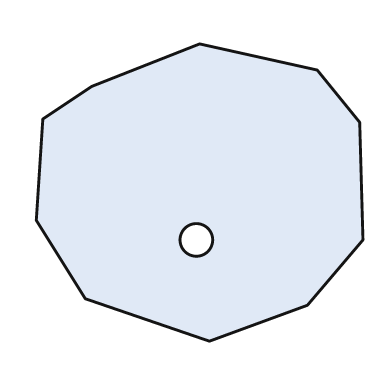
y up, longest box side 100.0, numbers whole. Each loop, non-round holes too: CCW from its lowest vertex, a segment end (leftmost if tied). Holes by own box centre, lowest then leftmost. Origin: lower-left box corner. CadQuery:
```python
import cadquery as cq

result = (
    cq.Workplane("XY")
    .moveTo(53.0, 0.0)
    .lineTo(83.0, 11.0)
    .lineTo(100.0, 31.0)
    .lineTo(99.0, 67.0)
    .lineTo(86.0, 83.0)
    .lineTo(50.0, 91.0)
    .lineTo(17.0, 78.0)
    .lineTo(2.0, 68.0)
    .lineTo(0.0, 37.0)
    .lineTo(15.0, 13.0)
    .close()
    .moveTo(49.0, 31.0)
    .circle(5.0)
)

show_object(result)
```